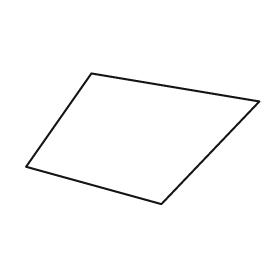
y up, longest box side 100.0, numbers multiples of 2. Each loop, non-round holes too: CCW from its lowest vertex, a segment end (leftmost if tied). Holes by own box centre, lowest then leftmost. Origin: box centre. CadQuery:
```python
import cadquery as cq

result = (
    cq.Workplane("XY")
    .moveTo(8.0, -28.0)
    .lineTo(50.0, 16.0)
    .lineTo(-22.0, 28.0)
    .lineTo(-50.0, -12.0)
    .close()
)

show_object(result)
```